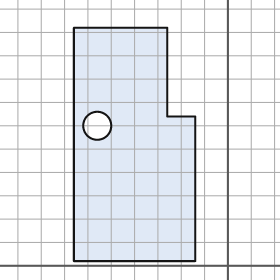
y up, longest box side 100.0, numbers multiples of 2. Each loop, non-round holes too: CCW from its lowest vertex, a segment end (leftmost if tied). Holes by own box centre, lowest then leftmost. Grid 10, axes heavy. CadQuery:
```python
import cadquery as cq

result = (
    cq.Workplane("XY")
    .moveTo(-66.0, 2.0)
    .lineTo(-14.0, 2.0)
    .lineTo(-14.0, 64.0)
    .lineTo(-26.0, 64.0)
    .lineTo(-26.0, 102.0)
    .lineTo(-66.0, 102.0)
    .close()
    .moveTo(-56.0, 60.0)
    .circle(6.0)
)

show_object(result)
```